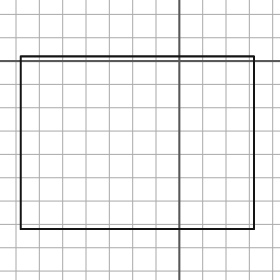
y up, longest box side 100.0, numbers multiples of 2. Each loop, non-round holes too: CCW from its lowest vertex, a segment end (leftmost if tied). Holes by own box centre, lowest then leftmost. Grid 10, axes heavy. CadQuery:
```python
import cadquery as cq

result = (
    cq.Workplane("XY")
    .moveTo(-68.0, -72.0)
    .lineTo(32.0, -72.0)
    .lineTo(32.0, 2.0)
    .lineTo(-68.0, 2.0)
    .close()
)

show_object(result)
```